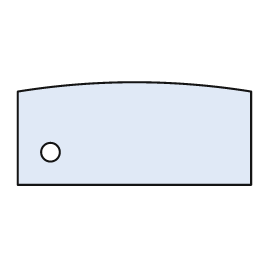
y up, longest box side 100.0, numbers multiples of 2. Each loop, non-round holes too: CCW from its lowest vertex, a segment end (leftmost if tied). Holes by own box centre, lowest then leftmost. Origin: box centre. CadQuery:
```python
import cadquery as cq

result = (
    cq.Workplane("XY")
    .moveTo(-50.0, -22.0)
    .lineTo(50.0, -22.0)
    .lineTo(50.0, 18.0)
    .threePointArc((0.0, 22.0), (-50.0, 18.0))
    .close()
    .moveTo(-36.0, -8.0)
    .circle(4.0)
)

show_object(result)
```